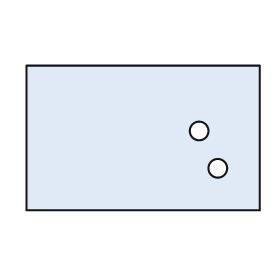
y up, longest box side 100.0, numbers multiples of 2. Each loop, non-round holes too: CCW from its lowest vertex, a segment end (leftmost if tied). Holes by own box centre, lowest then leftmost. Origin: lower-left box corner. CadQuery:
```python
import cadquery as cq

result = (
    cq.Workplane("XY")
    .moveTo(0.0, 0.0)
    .lineTo(100.0, 0.0)
    .lineTo(100.0, 62.0)
    .lineTo(0.0, 62.0)
    .close()
    .moveTo(82.0, 18.0)
    .circle(4.0)
    .moveTo(74.0, 34.0)
    .circle(4.0)
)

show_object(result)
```